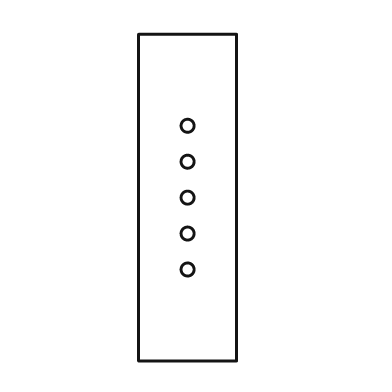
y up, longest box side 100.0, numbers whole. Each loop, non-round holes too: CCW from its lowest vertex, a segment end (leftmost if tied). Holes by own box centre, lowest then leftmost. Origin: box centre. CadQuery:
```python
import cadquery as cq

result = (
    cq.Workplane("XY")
    .moveTo(-15.0, -50.0)
    .lineTo(15.0, -50.0)
    .lineTo(15.0, 50.0)
    .lineTo(-15.0, 50.0)
    .close()
    .moveTo(0.0, -22.0)
    .circle(2.0)
    .moveTo(0.0, -11.0)
    .circle(2.0)
    .moveTo(0.0, 0.0)
    .circle(2.0)
    .moveTo(0.0, 11.0)
    .circle(2.0)
    .moveTo(0.0, 22.0)
    .circle(2.0)
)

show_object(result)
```